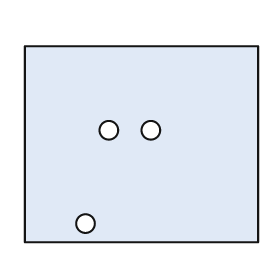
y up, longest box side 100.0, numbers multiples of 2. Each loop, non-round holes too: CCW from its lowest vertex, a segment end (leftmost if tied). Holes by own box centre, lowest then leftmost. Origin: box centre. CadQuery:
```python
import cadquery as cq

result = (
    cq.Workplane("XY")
    .moveTo(-50.0, -42.0)
    .lineTo(50.0, -42.0)
    .lineTo(50.0, 42.0)
    .lineTo(-50.0, 42.0)
    .close()
    .moveTo(-24.0, -34.0)
    .circle(4.0)
    .moveTo(-14.0, 6.0)
    .circle(4.0)
    .moveTo(4.0, 6.0)
    .circle(4.0)
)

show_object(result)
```